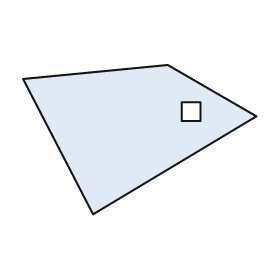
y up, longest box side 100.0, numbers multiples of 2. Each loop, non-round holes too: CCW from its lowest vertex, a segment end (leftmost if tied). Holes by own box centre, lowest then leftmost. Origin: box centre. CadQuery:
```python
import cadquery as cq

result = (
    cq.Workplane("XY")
    .moveTo(-20.0, -32.0)
    .lineTo(50.0, 10.0)
    .lineTo(12.0, 32.0)
    .lineTo(-50.0, 26.0)
    .close()
    .moveTo(18.0, 8.0)
    .lineTo(26.0, 8.0)
    .lineTo(26.0, 16.0)
    .lineTo(18.0, 16.0)
    .close()
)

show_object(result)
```